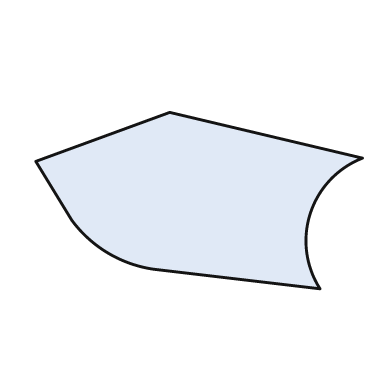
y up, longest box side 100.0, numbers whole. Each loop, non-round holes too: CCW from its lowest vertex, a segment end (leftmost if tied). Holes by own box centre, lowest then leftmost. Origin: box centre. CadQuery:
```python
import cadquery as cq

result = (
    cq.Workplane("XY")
    .moveTo(37.0, -27.0)
    .threePointArc((34.0, -4.0), (50.0, 13.0))
    .lineTo(-9.0, 27.0)
    .lineTo(-50.0, 12.0)
    .lineTo(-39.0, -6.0)
    .threePointArc((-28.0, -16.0), (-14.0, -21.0))
    .close()
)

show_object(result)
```